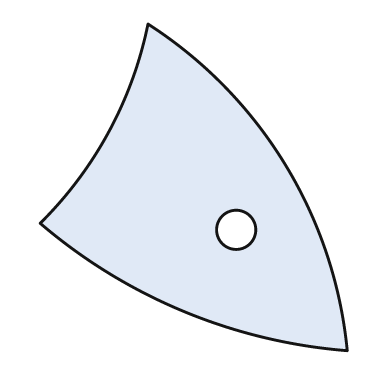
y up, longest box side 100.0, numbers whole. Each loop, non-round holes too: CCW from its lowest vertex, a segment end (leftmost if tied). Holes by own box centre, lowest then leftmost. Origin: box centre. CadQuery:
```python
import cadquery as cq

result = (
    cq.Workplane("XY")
    .moveTo(47.0, -50.0)
    .threePointArc((28.0, 7.0), (-14.0, 50.0))
    .threePointArc((-26.0, 17.0), (-47.0, -11.0))
    .threePointArc((-3.0, -38.0), (47.0, -50.0))
    .close()
    .moveTo(13.0, -13.0)
    .circle(6.0)
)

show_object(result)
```